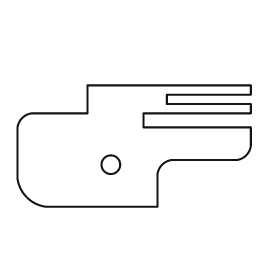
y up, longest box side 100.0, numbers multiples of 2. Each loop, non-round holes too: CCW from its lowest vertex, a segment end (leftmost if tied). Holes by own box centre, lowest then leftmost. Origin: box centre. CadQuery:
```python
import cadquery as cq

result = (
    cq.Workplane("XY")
    .moveTo(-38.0, -26.0)
    .lineTo(10.0, -26.0)
    .lineTo(10.0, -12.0)
    .threePointArc((12.0, -8.0), (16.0, -6.0))
    .lineTo(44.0, -6.0)
    .threePointArc((48.0, -4.0), (50.0, 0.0))
    .lineTo(50.0, 8.0)
    .lineTo(4.0, 8.0)
    .lineTo(4.0, 14.0)
    .lineTo(50.0, 14.0)
    .lineTo(50.0, 18.0)
    .lineTo(14.0, 18.0)
    .lineTo(14.0, 22.0)
    .lineTo(50.0, 22.0)
    .lineTo(50.0, 26.0)
    .lineTo(-20.0, 26.0)
    .lineTo(-20.0, 14.0)
    .lineTo(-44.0, 14.0)
    .threePointArc((-48.0, 12.0), (-50.0, 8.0))
    .lineTo(-50.0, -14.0)
    .threePointArc((-46.0, -22.0), (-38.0, -26.0))
    .close()
    .moveTo(-10.0, -8.0)
    .circle(4.0)
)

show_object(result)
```